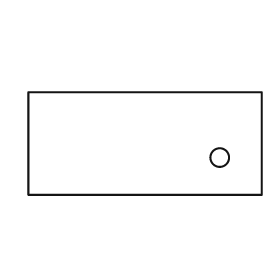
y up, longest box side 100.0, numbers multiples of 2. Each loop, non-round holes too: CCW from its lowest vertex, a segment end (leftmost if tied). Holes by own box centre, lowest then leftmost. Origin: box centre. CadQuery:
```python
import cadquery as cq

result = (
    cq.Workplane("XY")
    .moveTo(-50.0, -22.0)
    .lineTo(50.0, -22.0)
    .lineTo(50.0, 22.0)
    .lineTo(-50.0, 22.0)
    .close()
    .moveTo(32.0, -6.0)
    .circle(4.0)
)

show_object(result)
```